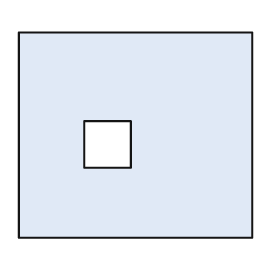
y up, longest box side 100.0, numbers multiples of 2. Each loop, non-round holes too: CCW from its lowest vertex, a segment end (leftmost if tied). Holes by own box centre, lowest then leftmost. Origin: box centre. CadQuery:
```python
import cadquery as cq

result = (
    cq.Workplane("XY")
    .moveTo(-50.0, -44.0)
    .lineTo(50.0, -44.0)
    .lineTo(50.0, 44.0)
    .lineTo(-50.0, 44.0)
    .close()
    .moveTo(-22.0, -14.0)
    .lineTo(-2.0, -14.0)
    .lineTo(-2.0, 6.0)
    .lineTo(-22.0, 6.0)
    .close()
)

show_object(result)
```